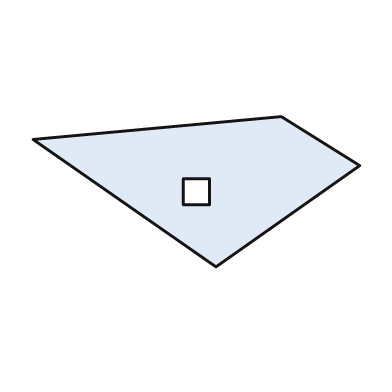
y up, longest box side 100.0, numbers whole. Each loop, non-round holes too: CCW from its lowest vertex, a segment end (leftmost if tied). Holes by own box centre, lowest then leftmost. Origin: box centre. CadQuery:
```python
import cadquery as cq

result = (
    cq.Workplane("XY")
    .moveTo(6.0, -23.0)
    .lineTo(50.0, 8.0)
    .lineTo(26.0, 23.0)
    .lineTo(-50.0, 16.0)
    .close()
    .moveTo(-4.0, -4.0)
    .lineTo(4.0, -4.0)
    .lineTo(4.0, 4.0)
    .lineTo(-4.0, 4.0)
    .close()
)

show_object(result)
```